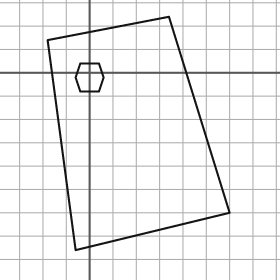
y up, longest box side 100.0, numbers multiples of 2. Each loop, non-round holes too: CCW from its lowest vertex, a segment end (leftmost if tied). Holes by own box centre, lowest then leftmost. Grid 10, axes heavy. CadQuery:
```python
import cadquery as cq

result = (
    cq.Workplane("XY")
    .moveTo(-6.0, -76.0)
    .lineTo(60.0, -60.0)
    .lineTo(34.0, 24.0)
    .lineTo(-18.0, 14.0)
    .close()
    .moveTo(-4.0, -8.0)
    .lineTo(4.0, -8.0)
    .lineTo(6.0, -2.0)
    .lineTo(4.0, 4.0)
    .lineTo(-4.0, 4.0)
    .lineTo(-6.0, -2.0)
    .close()
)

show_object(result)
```